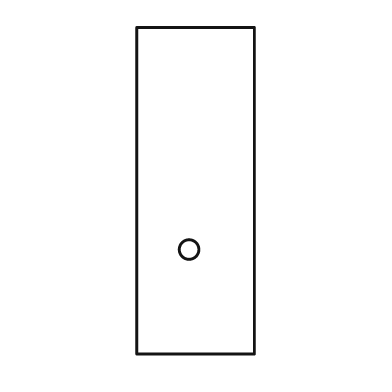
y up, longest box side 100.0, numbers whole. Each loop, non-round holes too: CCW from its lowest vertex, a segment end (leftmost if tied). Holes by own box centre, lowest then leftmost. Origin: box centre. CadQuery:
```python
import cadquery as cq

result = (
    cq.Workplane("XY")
    .moveTo(-18.0, -50.0)
    .lineTo(18.0, -50.0)
    .lineTo(18.0, 50.0)
    .lineTo(-18.0, 50.0)
    .close()
    .moveTo(-2.0, -18.0)
    .circle(3.0)
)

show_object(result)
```